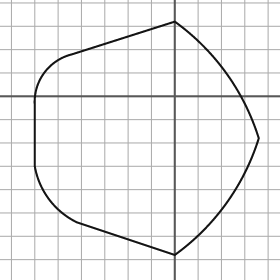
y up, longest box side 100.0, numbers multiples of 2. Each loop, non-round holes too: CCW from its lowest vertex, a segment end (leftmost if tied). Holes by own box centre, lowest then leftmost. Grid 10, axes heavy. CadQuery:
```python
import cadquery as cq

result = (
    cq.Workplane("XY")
    .moveTo(0.0, -68.0)
    .threePointArc((22.0, -46.0), (36.0, -18.0))
    .threePointArc((22.0, 10.0), (0.0, 32.0))
    .lineTo(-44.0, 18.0)
    .threePointArc((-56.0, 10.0), (-60.0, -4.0))
    .lineTo(-60.0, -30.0)
    .threePointArc((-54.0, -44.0), (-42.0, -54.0))
    .close()
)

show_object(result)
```